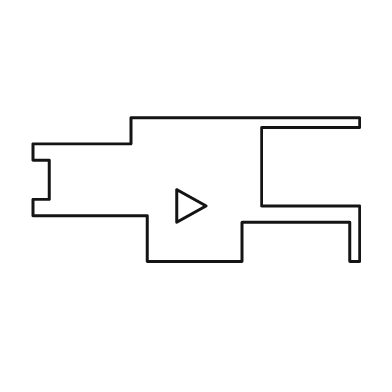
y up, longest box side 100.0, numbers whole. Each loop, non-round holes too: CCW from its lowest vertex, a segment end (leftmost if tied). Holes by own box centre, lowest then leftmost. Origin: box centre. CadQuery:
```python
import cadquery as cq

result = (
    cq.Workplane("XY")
    .moveTo(-15.0, -22.0)
    .lineTo(14.0, -22.0)
    .lineTo(14.0, -10.0)
    .lineTo(47.0, -10.0)
    .lineTo(47.0, -22.0)
    .lineTo(50.0, -22.0)
    .lineTo(50.0, -5.0)
    .lineTo(20.0, -5.0)
    .lineTo(20.0, 19.0)
    .lineTo(50.0, 19.0)
    .lineTo(50.0, 22.0)
    .lineTo(-20.0, 22.0)
    .lineTo(-20.0, 14.0)
    .lineTo(-50.0, 14.0)
    .lineTo(-50.0, 9.0)
    .lineTo(-45.0, 9.0)
    .lineTo(-45.0, -3.0)
    .lineTo(-50.0, -3.0)
    .lineTo(-50.0, -8.0)
    .lineTo(-15.0, -8.0)
    .close()
    .moveTo(-6.0, -10.0)
    .lineTo(3.0, -5.0)
    .lineTo(-6.0, 0.0)
    .close()
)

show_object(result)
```